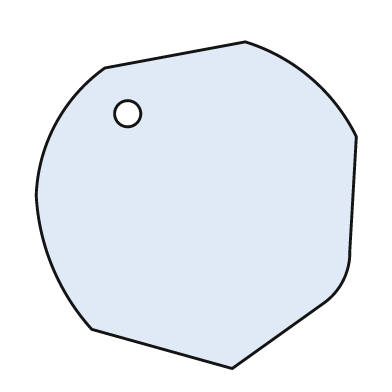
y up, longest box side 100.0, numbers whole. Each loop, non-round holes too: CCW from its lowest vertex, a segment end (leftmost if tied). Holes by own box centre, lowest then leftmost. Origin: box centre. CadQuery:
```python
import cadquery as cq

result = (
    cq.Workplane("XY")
    .moveTo(11.0, -50.0)
    .lineTo(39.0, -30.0)
    .threePointArc((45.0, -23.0), (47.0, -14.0))
    .lineTo(49.0, 21.0)
    .threePointArc((35.0, 39.0), (15.0, 50.0))
    .lineTo(-28.0, 42.0)
    .threePointArc((-43.0, 25.0), (-49.0, 3.0))
    .threePointArc((-44.0, -19.0), (-32.0, -38.0))
    .close()
    .moveTo(-21.0, 28.0)
    .circle(4.0)
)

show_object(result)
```